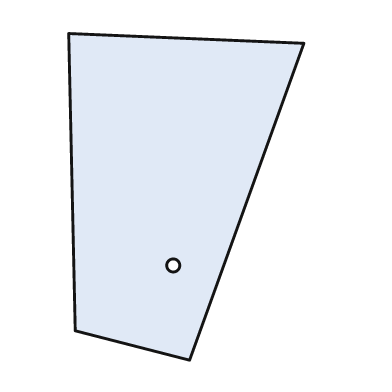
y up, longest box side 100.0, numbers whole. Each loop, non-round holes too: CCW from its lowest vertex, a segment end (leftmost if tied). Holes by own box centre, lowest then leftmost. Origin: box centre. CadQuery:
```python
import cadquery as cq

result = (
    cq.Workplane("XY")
    .moveTo(1.0, -50.0)
    .lineTo(36.0, 47.0)
    .lineTo(-36.0, 50.0)
    .lineTo(-34.0, -41.0)
    .close()
    .moveTo(-4.0, -21.0)
    .circle(2.0)
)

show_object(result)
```